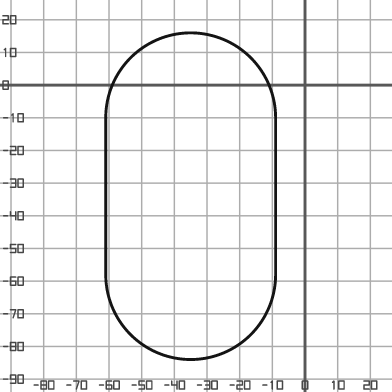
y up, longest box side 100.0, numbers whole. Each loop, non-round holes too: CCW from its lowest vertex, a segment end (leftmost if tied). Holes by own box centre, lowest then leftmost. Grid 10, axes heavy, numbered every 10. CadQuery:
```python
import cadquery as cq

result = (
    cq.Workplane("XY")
    .moveTo(-61.0, -58.0)
    .threePointArc((-35.0, -84.0), (-9.0, -58.0))
    .lineTo(-9.0, -10.0)
    .threePointArc((-35.0, 16.0), (-61.0, -10.0))
    .close()
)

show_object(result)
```